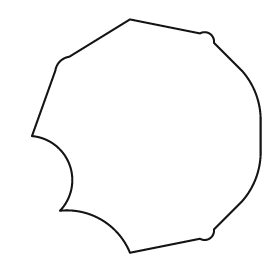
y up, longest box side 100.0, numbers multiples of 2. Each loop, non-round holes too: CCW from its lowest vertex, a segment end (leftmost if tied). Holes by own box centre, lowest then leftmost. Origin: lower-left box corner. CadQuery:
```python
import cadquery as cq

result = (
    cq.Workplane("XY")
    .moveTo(42.0, 0.0)
    .lineTo(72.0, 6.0)
    .threePointArc((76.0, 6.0), (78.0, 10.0))
    .lineTo(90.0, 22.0)
    .threePointArc((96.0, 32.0), (98.0, 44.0))
    .lineTo(98.0, 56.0)
    .threePointArc((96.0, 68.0), (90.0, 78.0))
    .lineTo(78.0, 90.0)
    .threePointArc((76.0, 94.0), (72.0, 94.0))
    .lineTo(42.0, 100.0)
    .lineTo(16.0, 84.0)
    .threePointArc((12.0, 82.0), (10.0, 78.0))
    .lineTo(0.0, 50.0)
    .threePointArc((16.0, 38.0), (12.0, 18.0))
    .threePointArc((30.0, 14.0), (42.0, 0.0))
    .close()
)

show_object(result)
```